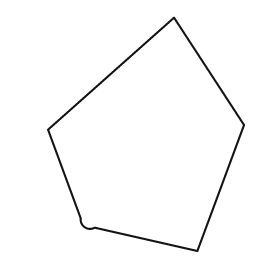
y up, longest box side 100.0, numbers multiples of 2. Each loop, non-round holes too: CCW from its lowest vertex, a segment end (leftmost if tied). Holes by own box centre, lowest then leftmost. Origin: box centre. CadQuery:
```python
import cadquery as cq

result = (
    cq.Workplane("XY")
    .moveTo(22.0, -50.0)
    .lineTo(42.0, 4.0)
    .lineTo(12.0, 50.0)
    .lineTo(-42.0, 2.0)
    .lineTo(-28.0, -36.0)
    .threePointArc((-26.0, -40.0), (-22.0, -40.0))
    .close()
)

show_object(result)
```